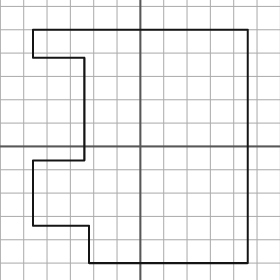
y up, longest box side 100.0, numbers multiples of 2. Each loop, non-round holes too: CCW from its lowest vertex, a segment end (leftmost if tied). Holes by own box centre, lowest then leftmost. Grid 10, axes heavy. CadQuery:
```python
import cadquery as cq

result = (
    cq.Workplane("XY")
    .moveTo(-22.0, -50.0)
    .lineTo(46.0, -50.0)
    .lineTo(46.0, 50.0)
    .lineTo(-46.0, 50.0)
    .lineTo(-46.0, 38.0)
    .lineTo(-24.0, 38.0)
    .lineTo(-24.0, -6.0)
    .lineTo(-46.0, -6.0)
    .lineTo(-46.0, -34.0)
    .lineTo(-22.0, -34.0)
    .close()
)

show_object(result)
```